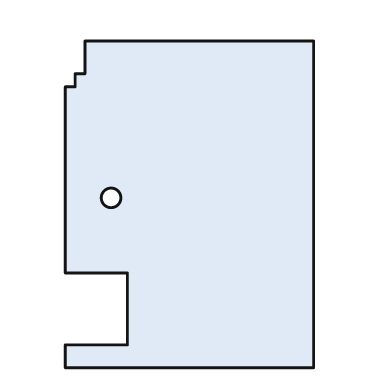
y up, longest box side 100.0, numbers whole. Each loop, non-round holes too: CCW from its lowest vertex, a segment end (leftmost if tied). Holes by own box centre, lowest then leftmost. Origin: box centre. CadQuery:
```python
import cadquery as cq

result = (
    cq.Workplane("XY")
    .moveTo(-38.0, -50.0)
    .lineTo(38.0, -50.0)
    .lineTo(38.0, 50.0)
    .lineTo(-32.0, 50.0)
    .lineTo(-32.0, 40.0)
    .lineTo(-35.0, 40.0)
    .lineTo(-35.0, 36.0)
    .lineTo(-38.0, 36.0)
    .lineTo(-38.0, -21.0)
    .lineTo(-19.0, -21.0)
    .lineTo(-19.0, -43.0)
    .lineTo(-38.0, -43.0)
    .close()
    .moveTo(-24.0, 2.0)
    .circle(3.0)
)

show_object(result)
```